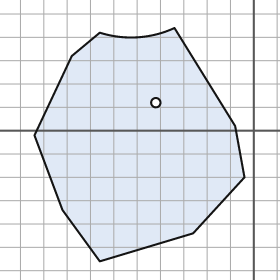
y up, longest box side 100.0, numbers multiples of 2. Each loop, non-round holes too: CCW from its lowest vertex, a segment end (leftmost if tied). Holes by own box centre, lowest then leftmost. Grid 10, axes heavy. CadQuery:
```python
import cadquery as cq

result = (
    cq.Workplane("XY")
    .moveTo(-66.0, -56.0)
    .lineTo(-26.0, -44.0)
    .lineTo(-4.0, -20.0)
    .lineTo(-8.0, 2.0)
    .lineTo(-34.0, 44.0)
    .threePointArc((-50.0, 40.0), (-66.0, 42.0))
    .lineTo(-78.0, 32.0)
    .lineTo(-94.0, -2.0)
    .lineTo(-82.0, -34.0)
    .close()
    .moveTo(-42.0, 12.0)
    .circle(2.0)
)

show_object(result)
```